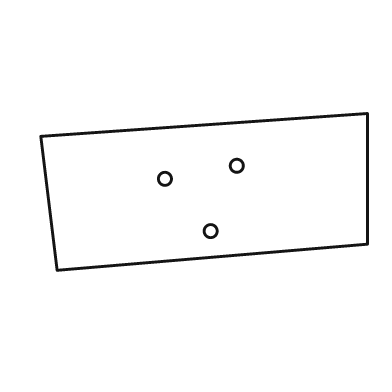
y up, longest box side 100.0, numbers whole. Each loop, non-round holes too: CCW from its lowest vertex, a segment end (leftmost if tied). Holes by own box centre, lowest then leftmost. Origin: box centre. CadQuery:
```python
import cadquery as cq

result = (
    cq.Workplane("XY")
    .moveTo(-45.0, -24.0)
    .lineTo(50.0, -16.0)
    .lineTo(50.0, 24.0)
    .lineTo(-50.0, 17.0)
    .close()
    .moveTo(2.0, -12.0)
    .circle(2.0)
    .moveTo(-12.0, 4.0)
    .circle(2.0)
    .moveTo(10.0, 8.0)
    .circle(2.0)
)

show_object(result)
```